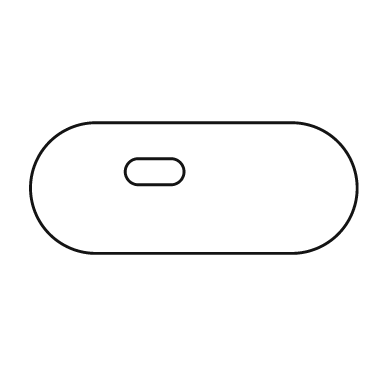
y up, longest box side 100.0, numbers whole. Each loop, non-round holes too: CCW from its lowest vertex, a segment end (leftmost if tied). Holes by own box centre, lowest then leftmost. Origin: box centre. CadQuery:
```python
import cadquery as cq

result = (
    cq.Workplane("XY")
    .moveTo(-30.0, -20.0)
    .lineTo(30.0, -20.0)
    .threePointArc((50.0, 0.0), (30.0, 20.0))
    .lineTo(-30.0, 20.0)
    .threePointArc((-50.0, 0.0), (-30.0, -20.0))
    .close()
    .moveTo(-17.0, 1.0)
    .lineTo(-7.0, 1.0)
    .threePointArc((-3.0, 5.0), (-7.0, 9.0))
    .lineTo(-17.0, 9.0)
    .threePointArc((-21.0, 5.0), (-17.0, 1.0))
    .close()
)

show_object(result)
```